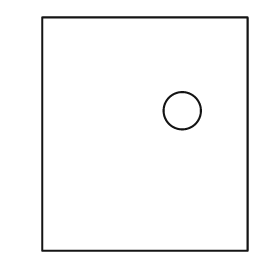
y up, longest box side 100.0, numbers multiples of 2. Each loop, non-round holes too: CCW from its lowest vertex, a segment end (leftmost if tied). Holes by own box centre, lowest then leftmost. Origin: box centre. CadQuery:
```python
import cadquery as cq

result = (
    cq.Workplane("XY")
    .moveTo(-44.0, -50.0)
    .lineTo(44.0, -50.0)
    .lineTo(44.0, 50.0)
    .lineTo(-44.0, 50.0)
    .close()
    .moveTo(16.0, 10.0)
    .circle(8.0)
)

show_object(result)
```